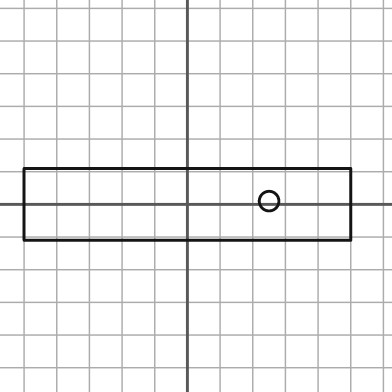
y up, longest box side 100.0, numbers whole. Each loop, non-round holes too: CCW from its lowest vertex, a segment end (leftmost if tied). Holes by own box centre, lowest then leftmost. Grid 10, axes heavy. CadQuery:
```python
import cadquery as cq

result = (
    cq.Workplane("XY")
    .moveTo(-50.0, -11.0)
    .lineTo(50.0, -11.0)
    .lineTo(50.0, 11.0)
    .lineTo(-50.0, 11.0)
    .close()
    .moveTo(25.0, 1.0)
    .circle(3.0)
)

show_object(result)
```